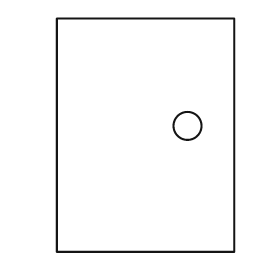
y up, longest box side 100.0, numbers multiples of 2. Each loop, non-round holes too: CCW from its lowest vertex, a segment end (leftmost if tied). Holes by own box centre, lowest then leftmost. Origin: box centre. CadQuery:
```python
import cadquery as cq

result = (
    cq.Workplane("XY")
    .moveTo(-38.0, -50.0)
    .lineTo(38.0, -50.0)
    .lineTo(38.0, 50.0)
    .lineTo(-38.0, 50.0)
    .close()
    .moveTo(18.0, 4.0)
    .circle(6.0)
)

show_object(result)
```